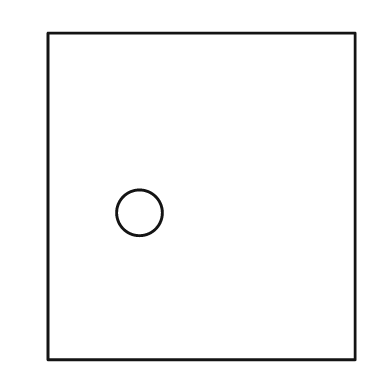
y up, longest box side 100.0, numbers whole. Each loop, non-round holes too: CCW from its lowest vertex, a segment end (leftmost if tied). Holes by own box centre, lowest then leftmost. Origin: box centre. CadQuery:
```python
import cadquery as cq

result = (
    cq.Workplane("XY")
    .moveTo(-47.0, -50.0)
    .lineTo(47.0, -50.0)
    .lineTo(47.0, 50.0)
    .lineTo(-47.0, 50.0)
    .close()
    .moveTo(-19.0, -5.0)
    .circle(7.0)
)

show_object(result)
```